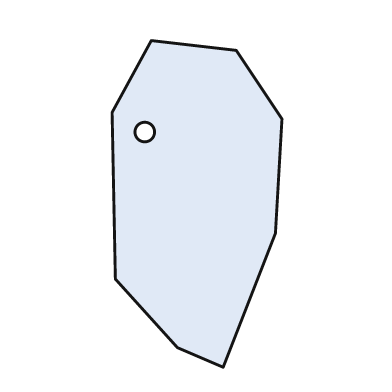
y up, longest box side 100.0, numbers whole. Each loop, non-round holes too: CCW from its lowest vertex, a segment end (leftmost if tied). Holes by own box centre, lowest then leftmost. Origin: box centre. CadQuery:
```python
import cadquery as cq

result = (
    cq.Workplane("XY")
    .moveTo(8.0, -50.0)
    .lineTo(24.0, -9.0)
    .lineTo(26.0, 26.0)
    .lineTo(12.0, 47.0)
    .lineTo(-14.0, 50.0)
    .lineTo(-26.0, 28.0)
    .lineTo(-25.0, -23.0)
    .lineTo(-6.0, -44.0)
    .close()
    .moveTo(-16.0, 22.0)
    .circle(3.0)
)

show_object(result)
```